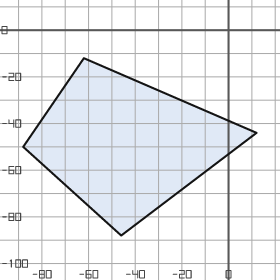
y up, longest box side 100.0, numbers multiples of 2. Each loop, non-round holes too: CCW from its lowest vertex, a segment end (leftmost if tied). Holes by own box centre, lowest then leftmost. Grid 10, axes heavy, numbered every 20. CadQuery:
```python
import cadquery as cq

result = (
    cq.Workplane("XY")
    .moveTo(-46.0, -88.0)
    .lineTo(12.0, -44.0)
    .lineTo(-62.0, -12.0)
    .lineTo(-88.0, -50.0)
    .close()
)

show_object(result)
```